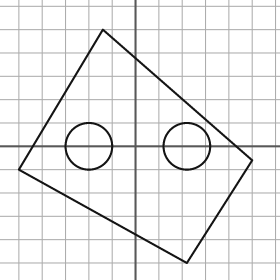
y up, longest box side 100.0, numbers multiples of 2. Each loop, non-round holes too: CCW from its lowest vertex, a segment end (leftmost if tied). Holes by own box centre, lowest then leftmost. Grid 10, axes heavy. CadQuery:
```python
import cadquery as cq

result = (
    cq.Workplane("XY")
    .moveTo(22.0, -50.0)
    .lineTo(50.0, -6.0)
    .lineTo(-14.0, 50.0)
    .lineTo(-50.0, -10.0)
    .close()
    .moveTo(-20.0, 0.0)
    .circle(10.0)
    .moveTo(22.0, 0.0)
    .circle(10.0)
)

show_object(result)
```